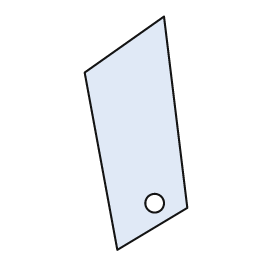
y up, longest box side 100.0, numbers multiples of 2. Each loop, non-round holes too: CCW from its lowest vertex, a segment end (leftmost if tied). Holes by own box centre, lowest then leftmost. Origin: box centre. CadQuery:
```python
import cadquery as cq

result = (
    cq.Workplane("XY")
    .moveTo(-8.0, -50.0)
    .lineTo(22.0, -32.0)
    .lineTo(12.0, 50.0)
    .lineTo(-22.0, 26.0)
    .close()
    .moveTo(8.0, -30.0)
    .circle(4.0)
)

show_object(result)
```